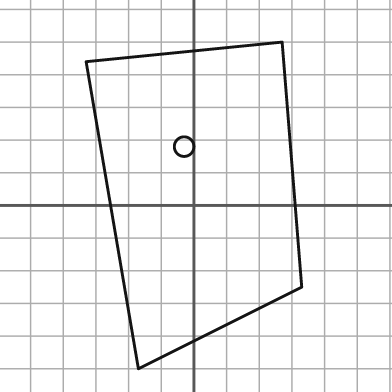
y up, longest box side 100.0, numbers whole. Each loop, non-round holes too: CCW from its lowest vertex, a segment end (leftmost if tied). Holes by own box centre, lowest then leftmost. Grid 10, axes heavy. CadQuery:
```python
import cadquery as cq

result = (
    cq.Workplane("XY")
    .moveTo(-17.0, -50.0)
    .lineTo(33.0, -25.0)
    .lineTo(27.0, 50.0)
    .lineTo(-33.0, 44.0)
    .close()
    .moveTo(-3.0, 18.0)
    .circle(3.0)
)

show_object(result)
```